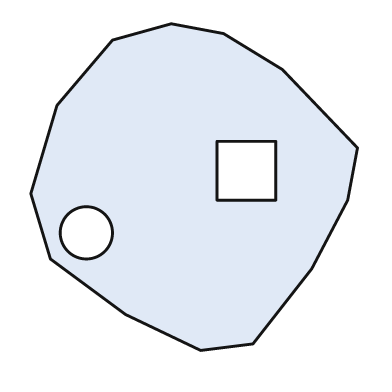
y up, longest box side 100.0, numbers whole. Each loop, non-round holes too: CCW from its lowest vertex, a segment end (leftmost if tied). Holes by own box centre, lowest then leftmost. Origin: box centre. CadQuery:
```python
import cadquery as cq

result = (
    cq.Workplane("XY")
    .moveTo(2.0, -50.0)
    .lineTo(18.0, -48.0)
    .lineTo(36.0, -25.0)
    .lineTo(47.0, -4.0)
    .lineTo(50.0, 12.0)
    .lineTo(27.0, 36.0)
    .lineTo(9.0, 47.0)
    .lineTo(-7.0, 50.0)
    .lineTo(-25.0, 45.0)
    .lineTo(-42.0, 25.0)
    .lineTo(-50.0, -2.0)
    .lineTo(-44.0, -22.0)
    .lineTo(-21.0, -39.0)
    .close()
    .moveTo(-33.0, -14.0)
    .circle(8.0)
    .moveTo(7.0, -4.0)
    .lineTo(25.0, -4.0)
    .lineTo(25.0, 14.0)
    .lineTo(7.0, 14.0)
    .close()
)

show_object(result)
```